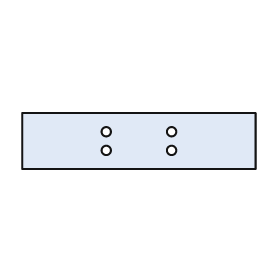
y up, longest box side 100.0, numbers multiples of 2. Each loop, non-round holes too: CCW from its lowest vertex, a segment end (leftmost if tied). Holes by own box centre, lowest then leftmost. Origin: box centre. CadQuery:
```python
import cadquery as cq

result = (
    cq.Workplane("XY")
    .moveTo(-50.0, -12.0)
    .lineTo(50.0, -12.0)
    .lineTo(50.0, 12.0)
    .lineTo(-50.0, 12.0)
    .close()
    .moveTo(-14.0, -4.0)
    .circle(2.0)
    .moveTo(14.0, -4.0)
    .circle(2.0)
    .moveTo(-14.0, 4.0)
    .circle(2.0)
    .moveTo(14.0, 4.0)
    .circle(2.0)
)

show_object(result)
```